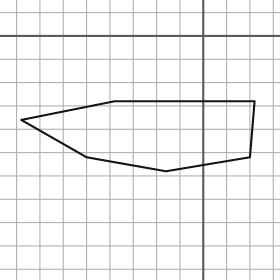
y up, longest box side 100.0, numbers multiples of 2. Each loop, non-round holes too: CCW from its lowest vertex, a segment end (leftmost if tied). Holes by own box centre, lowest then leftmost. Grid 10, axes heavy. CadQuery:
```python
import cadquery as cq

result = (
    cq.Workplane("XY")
    .moveTo(-16.0, -58.0)
    .lineTo(20.0, -52.0)
    .lineTo(22.0, -28.0)
    .lineTo(-38.0, -28.0)
    .lineTo(-78.0, -36.0)
    .lineTo(-50.0, -52.0)
    .close()
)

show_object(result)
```